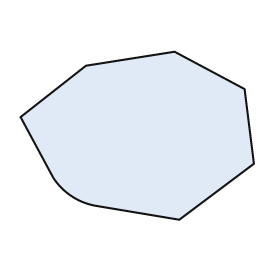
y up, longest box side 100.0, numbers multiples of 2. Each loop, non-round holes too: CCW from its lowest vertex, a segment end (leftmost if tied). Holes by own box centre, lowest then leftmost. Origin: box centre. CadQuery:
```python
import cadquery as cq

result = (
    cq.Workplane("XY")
    .moveTo(18.0, -36.0)
    .lineTo(50.0, -12.0)
    .lineTo(46.0, 20.0)
    .lineTo(16.0, 36.0)
    .lineTo(-22.0, 30.0)
    .lineTo(-50.0, 8.0)
    .lineTo(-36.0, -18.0)
    .threePointArc((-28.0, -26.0), (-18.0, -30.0))
    .close()
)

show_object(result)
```